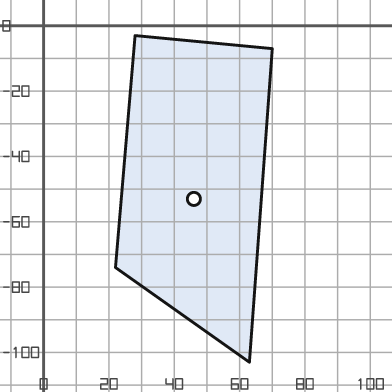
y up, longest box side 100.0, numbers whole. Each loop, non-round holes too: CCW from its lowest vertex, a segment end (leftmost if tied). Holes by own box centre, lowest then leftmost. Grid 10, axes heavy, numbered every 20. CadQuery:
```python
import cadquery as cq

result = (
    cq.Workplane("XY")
    .moveTo(63.0, -103.0)
    .lineTo(70.0, -7.0)
    .lineTo(28.0, -3.0)
    .lineTo(22.0, -74.0)
    .close()
    .moveTo(46.0, -53.0)
    .circle(2.0)
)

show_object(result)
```